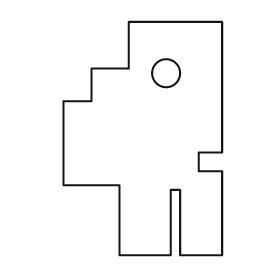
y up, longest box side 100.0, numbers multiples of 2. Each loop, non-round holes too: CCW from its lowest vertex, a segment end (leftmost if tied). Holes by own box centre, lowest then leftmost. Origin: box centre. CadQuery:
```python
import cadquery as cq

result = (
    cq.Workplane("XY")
    .moveTo(-10.0, -50.0)
    .lineTo(12.0, -50.0)
    .lineTo(12.0, -22.0)
    .lineTo(16.0, -22.0)
    .lineTo(16.0, -50.0)
    .lineTo(34.0, -50.0)
    .lineTo(34.0, -14.0)
    .lineTo(24.0, -14.0)
    .lineTo(24.0, -6.0)
    .lineTo(34.0, -6.0)
    .lineTo(34.0, 50.0)
    .lineTo(-6.0, 50.0)
    .lineTo(-6.0, 30.0)
    .lineTo(-22.0, 30.0)
    .lineTo(-22.0, 16.0)
    .lineTo(-34.0, 16.0)
    .lineTo(-34.0, -20.0)
    .lineTo(-10.0, -20.0)
    .close()
    .moveTo(10.0, 28.0)
    .circle(6.0)
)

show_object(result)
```